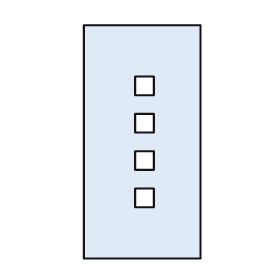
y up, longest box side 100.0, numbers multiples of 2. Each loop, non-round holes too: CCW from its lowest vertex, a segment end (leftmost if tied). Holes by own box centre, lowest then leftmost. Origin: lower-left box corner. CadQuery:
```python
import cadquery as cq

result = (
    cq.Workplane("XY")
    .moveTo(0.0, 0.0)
    .lineTo(50.0, 0.0)
    .lineTo(50.0, 100.0)
    .lineTo(0.0, 100.0)
    .close()
    .moveTo(22.0, 22.0)
    .lineTo(30.0, 22.0)
    .lineTo(30.0, 30.0)
    .lineTo(22.0, 30.0)
    .close()
    .moveTo(22.0, 38.0)
    .lineTo(30.0, 38.0)
    .lineTo(30.0, 46.0)
    .lineTo(22.0, 46.0)
    .close()
    .moveTo(22.0, 54.0)
    .lineTo(30.0, 54.0)
    .lineTo(30.0, 62.0)
    .lineTo(22.0, 62.0)
    .close()
    .moveTo(22.0, 70.0)
    .lineTo(30.0, 70.0)
    .lineTo(30.0, 78.0)
    .lineTo(22.0, 78.0)
    .close()
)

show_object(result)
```